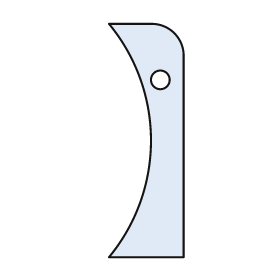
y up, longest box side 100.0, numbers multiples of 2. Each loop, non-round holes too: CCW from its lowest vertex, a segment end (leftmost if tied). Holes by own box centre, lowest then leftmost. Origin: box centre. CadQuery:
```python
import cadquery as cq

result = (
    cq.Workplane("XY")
    .moveTo(-16.0, -50.0)
    .lineTo(16.0, -50.0)
    .lineTo(16.0, 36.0)
    .threePointArc((12.0, 46.0), (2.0, 50.0))
    .lineTo(-16.0, 50.0)
    .threePointArc((2.0, 0.0), (-16.0, -50.0))
    .close()
    .moveTo(6.0, 26.0)
    .circle(4.0)
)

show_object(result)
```